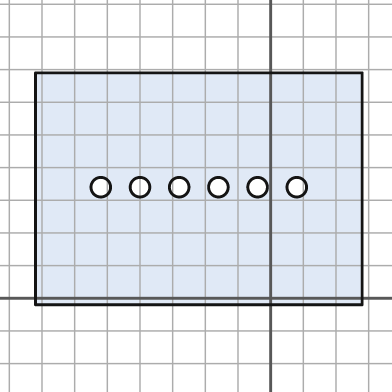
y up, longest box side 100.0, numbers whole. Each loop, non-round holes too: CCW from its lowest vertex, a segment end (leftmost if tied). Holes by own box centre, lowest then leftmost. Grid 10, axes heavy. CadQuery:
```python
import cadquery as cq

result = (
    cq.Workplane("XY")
    .moveTo(-72.0, -2.0)
    .lineTo(28.0, -2.0)
    .lineTo(28.0, 69.0)
    .lineTo(-72.0, 69.0)
    .close()
    .moveTo(-52.0, 34.0)
    .circle(3.0)
    .moveTo(-40.0, 34.0)
    .circle(3.0)
    .moveTo(-28.0, 34.0)
    .circle(3.0)
    .moveTo(-16.0, 34.0)
    .circle(3.0)
    .moveTo(-4.0, 34.0)
    .circle(3.0)
    .moveTo(8.0, 34.0)
    .circle(3.0)
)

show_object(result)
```